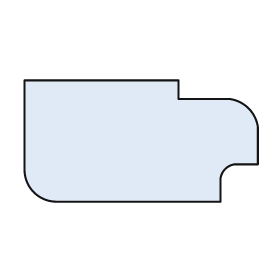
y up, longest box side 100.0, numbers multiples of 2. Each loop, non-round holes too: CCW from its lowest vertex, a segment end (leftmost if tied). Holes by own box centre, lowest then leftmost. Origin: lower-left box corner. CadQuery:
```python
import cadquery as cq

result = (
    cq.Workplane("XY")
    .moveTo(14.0, 0.0)
    .lineTo(84.0, 0.0)
    .lineTo(84.0, 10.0)
    .threePointArc((86.0, 14.0), (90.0, 16.0))
    .lineTo(100.0, 16.0)
    .lineTo(100.0, 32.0)
    .threePointArc((96.0, 40.0), (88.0, 44.0))
    .lineTo(66.0, 44.0)
    .lineTo(66.0, 52.0)
    .lineTo(0.0, 52.0)
    .lineTo(0.0, 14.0)
    .threePointArc((4.0, 4.0), (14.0, 0.0))
    .close()
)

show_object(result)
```